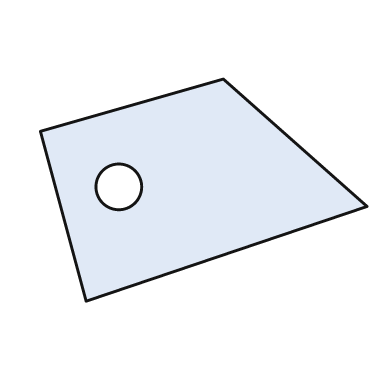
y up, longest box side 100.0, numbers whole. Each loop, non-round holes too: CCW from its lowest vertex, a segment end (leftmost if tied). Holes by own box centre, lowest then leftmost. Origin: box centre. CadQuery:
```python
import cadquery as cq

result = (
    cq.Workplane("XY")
    .moveTo(-36.0, -34.0)
    .lineTo(50.0, -5.0)
    .lineTo(6.0, 34.0)
    .lineTo(-50.0, 18.0)
    .close()
    .moveTo(-26.0, 1.0)
    .circle(7.0)
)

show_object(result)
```